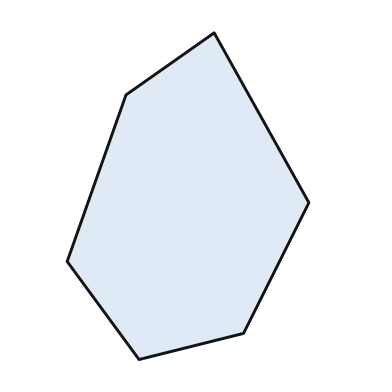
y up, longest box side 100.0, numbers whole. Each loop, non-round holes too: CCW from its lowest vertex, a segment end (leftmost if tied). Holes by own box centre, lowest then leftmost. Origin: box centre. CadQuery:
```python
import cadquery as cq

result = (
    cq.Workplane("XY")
    .moveTo(-15.0, -50.0)
    .lineTo(17.0, -42.0)
    .lineTo(37.0, -2.0)
    .lineTo(8.0, 50.0)
    .lineTo(-19.0, 31.0)
    .lineTo(-37.0, -20.0)
    .close()
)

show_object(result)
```